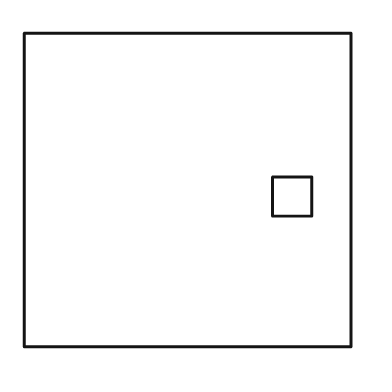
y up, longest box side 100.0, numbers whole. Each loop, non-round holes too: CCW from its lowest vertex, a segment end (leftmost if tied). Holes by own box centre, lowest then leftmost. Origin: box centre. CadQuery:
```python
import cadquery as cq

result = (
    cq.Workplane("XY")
    .moveTo(-50.0, -48.0)
    .lineTo(50.0, -48.0)
    .lineTo(50.0, 48.0)
    .lineTo(-50.0, 48.0)
    .close()
    .moveTo(26.0, -8.0)
    .lineTo(38.0, -8.0)
    .lineTo(38.0, 4.0)
    .lineTo(26.0, 4.0)
    .close()
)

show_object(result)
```